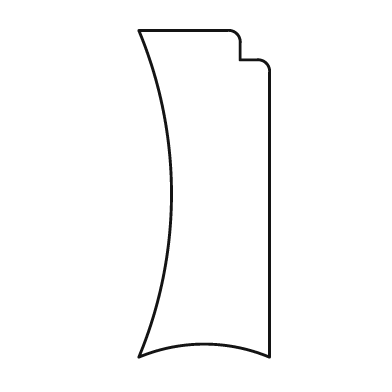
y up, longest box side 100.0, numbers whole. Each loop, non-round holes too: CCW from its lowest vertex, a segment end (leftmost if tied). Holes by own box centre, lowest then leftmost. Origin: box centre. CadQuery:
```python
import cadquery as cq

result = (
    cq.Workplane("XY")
    .moveTo(-20.0, -50.0)
    .threePointArc((0.0, -46.0), (20.0, -50.0))
    .lineTo(20.0, 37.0)
    .threePointArc((19.0, 40.0), (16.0, 41.0))
    .lineTo(11.0, 41.0)
    .lineTo(11.0, 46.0)
    .threePointArc((10.0, 49.0), (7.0, 50.0))
    .lineTo(-20.0, 50.0)
    .threePointArc((-10.0, 0.0), (-20.0, -50.0))
    .close()
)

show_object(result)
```